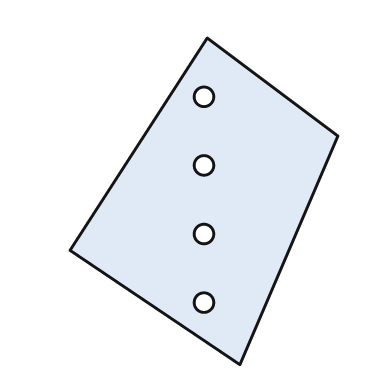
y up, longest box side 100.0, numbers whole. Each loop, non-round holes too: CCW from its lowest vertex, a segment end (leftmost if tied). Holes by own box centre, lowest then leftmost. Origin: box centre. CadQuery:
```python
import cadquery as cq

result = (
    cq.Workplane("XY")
    .moveTo(11.0, -50.0)
    .lineTo(41.0, 20.0)
    .lineTo(1.0, 50.0)
    .lineTo(-41.0, -15.0)
    .close()
    .moveTo(0.0, -31.0)
    .circle(3.0)
    .moveTo(0.0, -10.0)
    .circle(3.0)
    .moveTo(0.0, 11.0)
    .circle(3.0)
    .moveTo(0.0, 32.0)
    .circle(3.0)
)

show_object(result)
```